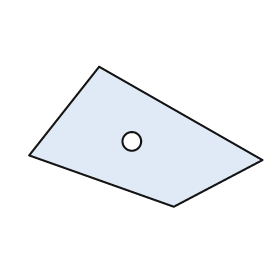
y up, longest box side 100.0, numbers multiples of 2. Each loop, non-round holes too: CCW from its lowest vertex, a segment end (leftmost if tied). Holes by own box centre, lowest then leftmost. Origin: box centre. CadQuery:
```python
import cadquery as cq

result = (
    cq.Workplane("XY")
    .moveTo(12.0, -30.0)
    .lineTo(50.0, -10.0)
    .lineTo(-20.0, 30.0)
    .lineTo(-50.0, -8.0)
    .close()
    .moveTo(-6.0, -2.0)
    .circle(4.0)
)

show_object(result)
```